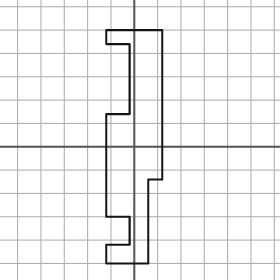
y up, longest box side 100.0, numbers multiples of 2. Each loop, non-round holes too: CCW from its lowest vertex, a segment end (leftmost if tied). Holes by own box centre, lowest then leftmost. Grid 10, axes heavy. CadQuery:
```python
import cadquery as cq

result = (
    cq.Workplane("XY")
    .moveTo(-12.0, -50.0)
    .lineTo(6.0, -50.0)
    .lineTo(6.0, -14.0)
    .lineTo(12.0, -14.0)
    .lineTo(12.0, 50.0)
    .lineTo(-12.0, 50.0)
    .lineTo(-12.0, 44.0)
    .lineTo(-2.0, 44.0)
    .lineTo(-2.0, 14.0)
    .lineTo(-12.0, 14.0)
    .lineTo(-12.0, -30.0)
    .lineTo(-2.0, -30.0)
    .lineTo(-2.0, -42.0)
    .lineTo(-12.0, -42.0)
    .close()
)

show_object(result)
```